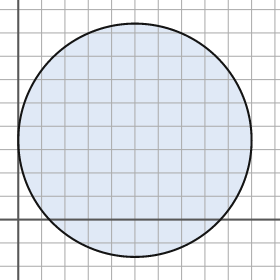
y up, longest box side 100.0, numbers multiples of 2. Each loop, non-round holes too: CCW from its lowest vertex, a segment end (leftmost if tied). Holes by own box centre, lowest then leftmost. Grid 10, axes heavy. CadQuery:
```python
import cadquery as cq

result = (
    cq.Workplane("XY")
    .moveTo(50.0, 34.0)
    .circle(50.0)
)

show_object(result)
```